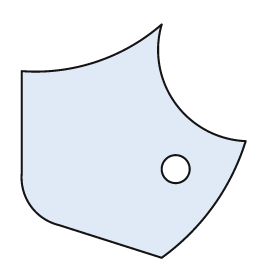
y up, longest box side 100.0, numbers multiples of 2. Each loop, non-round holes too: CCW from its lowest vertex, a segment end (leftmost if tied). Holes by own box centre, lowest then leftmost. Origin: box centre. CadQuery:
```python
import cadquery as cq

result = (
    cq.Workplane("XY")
    .moveTo(12.0, -50.0)
    .threePointArc((34.0, -28.0), (48.0, 0.0))
    .threePointArc((18.0, 16.0), (12.0, 50.0))
    .threePointArc((-16.0, 34.0), (-48.0, 30.0))
    .lineTo(-48.0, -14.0)
    .threePointArc((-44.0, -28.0), (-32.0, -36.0))
    .close()
    .moveTo(18.0, -12.0)
    .circle(6.0)
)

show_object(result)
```